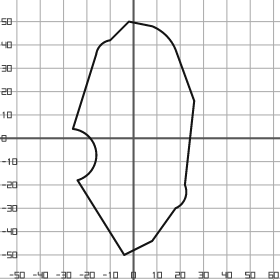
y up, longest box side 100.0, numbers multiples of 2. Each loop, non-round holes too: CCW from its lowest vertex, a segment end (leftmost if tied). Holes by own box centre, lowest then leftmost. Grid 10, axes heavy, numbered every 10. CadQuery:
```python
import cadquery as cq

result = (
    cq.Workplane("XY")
    .moveTo(-4.0, -50.0)
    .lineTo(8.0, -44.0)
    .lineTo(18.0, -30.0)
    .threePointArc((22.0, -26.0), (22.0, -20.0))
    .lineTo(26.0, 16.0)
    .lineTo(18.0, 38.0)
    .threePointArc((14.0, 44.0), (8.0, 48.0))
    .lineTo(-2.0, 50.0)
    .lineTo(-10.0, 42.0)
    .threePointArc((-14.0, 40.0), (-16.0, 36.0))
    .lineTo(-26.0, 4.0)
    .threePointArc((-16.0, -6.0), (-24.0, -18.0))
    .close()
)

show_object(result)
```